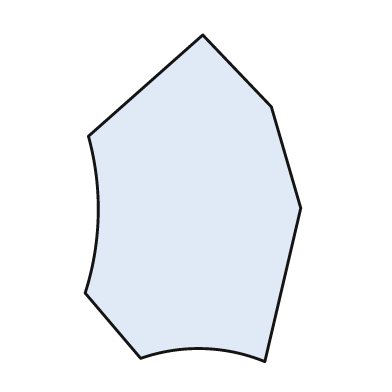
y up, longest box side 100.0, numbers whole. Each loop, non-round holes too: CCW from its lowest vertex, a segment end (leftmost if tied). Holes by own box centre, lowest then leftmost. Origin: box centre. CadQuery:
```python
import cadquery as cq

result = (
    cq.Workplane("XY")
    .moveTo(22.0, -50.0)
    .lineTo(33.0, -3.0)
    .lineTo(24.0, 28.0)
    .lineTo(3.0, 50.0)
    .lineTo(-32.0, 19.0)
    .threePointArc((-29.0, -5.0), (-33.0, -29.0))
    .lineTo(-16.0, -49.0)
    .threePointArc((3.0, -46.0), (22.0, -50.0))
    .close()
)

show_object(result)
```